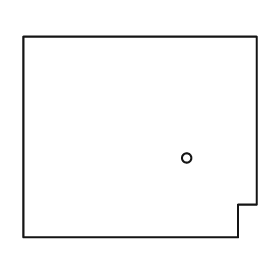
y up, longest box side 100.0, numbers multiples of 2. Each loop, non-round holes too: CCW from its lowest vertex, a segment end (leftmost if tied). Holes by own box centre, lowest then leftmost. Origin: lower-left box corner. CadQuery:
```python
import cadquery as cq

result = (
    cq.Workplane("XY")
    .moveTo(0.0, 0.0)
    .lineTo(92.0, 0.0)
    .lineTo(92.0, 14.0)
    .lineTo(100.0, 14.0)
    .lineTo(100.0, 86.0)
    .lineTo(0.0, 86.0)
    .close()
    .moveTo(70.0, 34.0)
    .circle(2.0)
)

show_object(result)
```